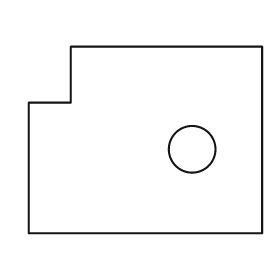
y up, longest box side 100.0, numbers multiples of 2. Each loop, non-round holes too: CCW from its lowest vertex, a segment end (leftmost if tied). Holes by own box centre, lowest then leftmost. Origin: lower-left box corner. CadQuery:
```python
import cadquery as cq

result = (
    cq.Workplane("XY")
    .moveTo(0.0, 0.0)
    .lineTo(100.0, 0.0)
    .lineTo(100.0, 80.0)
    .lineTo(18.0, 80.0)
    .lineTo(18.0, 56.0)
    .lineTo(0.0, 56.0)
    .close()
    .moveTo(70.0, 36.0)
    .circle(10.0)
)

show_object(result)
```